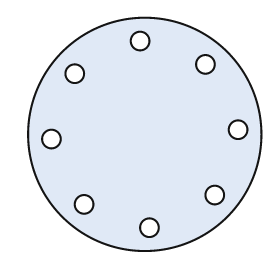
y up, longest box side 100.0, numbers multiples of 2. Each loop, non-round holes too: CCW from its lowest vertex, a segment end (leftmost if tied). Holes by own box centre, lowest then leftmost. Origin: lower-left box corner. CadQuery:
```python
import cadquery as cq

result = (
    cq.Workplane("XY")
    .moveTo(50.0, 50.0)
    .circle(50.0)
    .moveTo(52.0, 10.0)
    .circle(4.0)
    .moveTo(24.0, 20.0)
    .circle(4.0)
    .moveTo(80.0, 24.0)
    .circle(4.0)
    .moveTo(10.0, 48.0)
    .circle(4.0)
    .moveTo(90.0, 52.0)
    .circle(4.0)
    .moveTo(20.0, 76.0)
    .circle(4.0)
    .moveTo(76.0, 80.0)
    .circle(4.0)
    .moveTo(48.0, 90.0)
    .circle(4.0)
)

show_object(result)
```